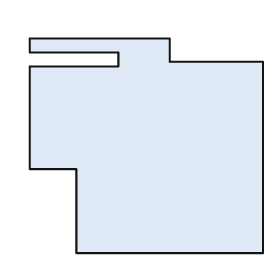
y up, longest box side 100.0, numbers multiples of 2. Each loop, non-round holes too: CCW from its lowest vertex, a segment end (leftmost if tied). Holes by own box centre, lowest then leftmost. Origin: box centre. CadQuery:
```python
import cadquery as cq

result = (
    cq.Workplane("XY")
    .moveTo(-30.0, -46.0)
    .lineTo(50.0, -46.0)
    .lineTo(50.0, 36.0)
    .lineTo(10.0, 36.0)
    .lineTo(10.0, 46.0)
    .lineTo(-50.0, 46.0)
    .lineTo(-50.0, 40.0)
    .lineTo(-12.0, 40.0)
    .lineTo(-12.0, 34.0)
    .lineTo(-50.0, 34.0)
    .lineTo(-50.0, -10.0)
    .lineTo(-30.0, -10.0)
    .close()
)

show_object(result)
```